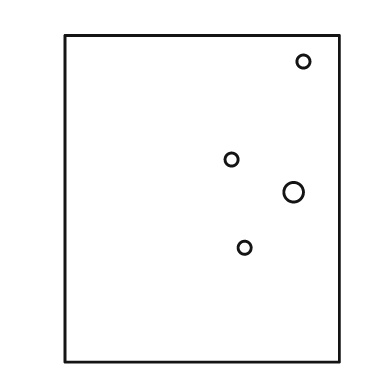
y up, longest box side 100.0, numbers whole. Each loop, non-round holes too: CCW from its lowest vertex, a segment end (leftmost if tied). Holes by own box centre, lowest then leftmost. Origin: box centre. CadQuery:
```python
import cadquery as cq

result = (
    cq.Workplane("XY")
    .moveTo(-42.0, -50.0)
    .lineTo(42.0, -50.0)
    .lineTo(42.0, 50.0)
    .lineTo(-42.0, 50.0)
    .close()
    .moveTo(13.0, -15.0)
    .circle(2.0)
    .moveTo(28.0, 2.0)
    .circle(3.0)
    .moveTo(9.0, 12.0)
    .circle(2.0)
    .moveTo(31.0, 42.0)
    .circle(2.0)
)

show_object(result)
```